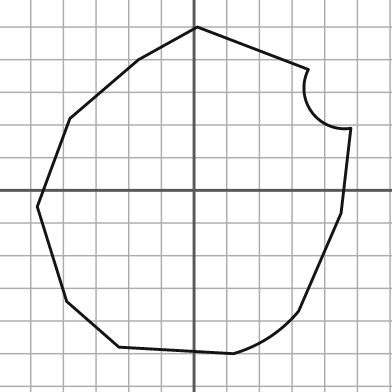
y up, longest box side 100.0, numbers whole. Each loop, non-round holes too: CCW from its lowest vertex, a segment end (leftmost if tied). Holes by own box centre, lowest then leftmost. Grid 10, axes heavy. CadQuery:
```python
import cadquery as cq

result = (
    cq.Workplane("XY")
    .moveTo(12.0, -50.0)
    .threePointArc((23.0, -45.0), (32.0, -37.0))
    .lineTo(45.0, -7.0)
    .lineTo(48.0, 19.0)
    .threePointArc((36.0, 24.0), (35.0, 37.0))
    .lineTo(1.0, 50.0)
    .lineTo(-17.0, 40.0)
    .lineTo(-38.0, 22.0)
    .lineTo(-48.0, -5.0)
    .lineTo(-39.0, -34.0)
    .lineTo(-23.0, -48.0)
    .close()
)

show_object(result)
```